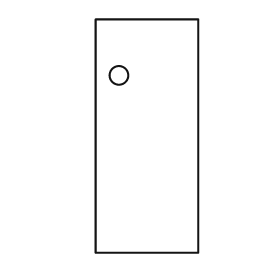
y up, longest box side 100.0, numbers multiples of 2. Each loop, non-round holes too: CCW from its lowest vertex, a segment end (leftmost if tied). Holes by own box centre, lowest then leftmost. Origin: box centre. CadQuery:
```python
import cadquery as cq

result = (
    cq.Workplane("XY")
    .moveTo(-22.0, -50.0)
    .lineTo(22.0, -50.0)
    .lineTo(22.0, 50.0)
    .lineTo(-22.0, 50.0)
    .close()
    .moveTo(-12.0, 26.0)
    .circle(4.0)
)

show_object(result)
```